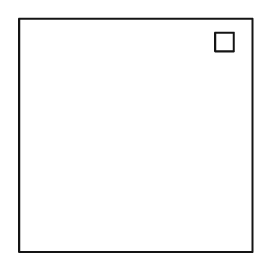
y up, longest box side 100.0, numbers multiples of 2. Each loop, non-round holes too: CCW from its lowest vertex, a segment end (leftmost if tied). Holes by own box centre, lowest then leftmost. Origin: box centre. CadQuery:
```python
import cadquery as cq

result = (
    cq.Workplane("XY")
    .moveTo(-50.0, -50.0)
    .lineTo(50.0, -50.0)
    .lineTo(50.0, 50.0)
    .lineTo(-50.0, 50.0)
    .close()
    .moveTo(34.0, 36.0)
    .lineTo(42.0, 36.0)
    .lineTo(42.0, 44.0)
    .lineTo(34.0, 44.0)
    .close()
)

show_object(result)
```